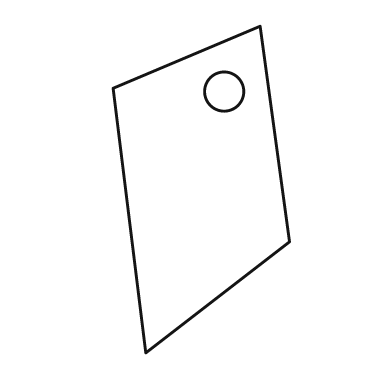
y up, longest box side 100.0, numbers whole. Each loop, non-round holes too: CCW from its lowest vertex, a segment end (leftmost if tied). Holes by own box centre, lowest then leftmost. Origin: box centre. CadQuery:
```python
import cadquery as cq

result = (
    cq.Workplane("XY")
    .moveTo(-17.0, -50.0)
    .lineTo(27.0, -16.0)
    .lineTo(18.0, 50.0)
    .lineTo(-27.0, 31.0)
    .close()
    .moveTo(7.0, 30.0)
    .circle(6.0)
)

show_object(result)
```